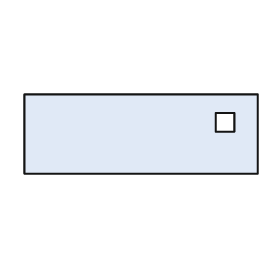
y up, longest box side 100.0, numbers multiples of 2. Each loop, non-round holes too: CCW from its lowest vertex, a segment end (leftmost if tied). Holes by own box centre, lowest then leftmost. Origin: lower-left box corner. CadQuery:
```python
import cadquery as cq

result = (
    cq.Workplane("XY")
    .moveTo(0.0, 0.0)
    .lineTo(100.0, 0.0)
    .lineTo(100.0, 34.0)
    .lineTo(0.0, 34.0)
    .close()
    .moveTo(82.0, 18.0)
    .lineTo(90.0, 18.0)
    .lineTo(90.0, 26.0)
    .lineTo(82.0, 26.0)
    .close()
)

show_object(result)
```